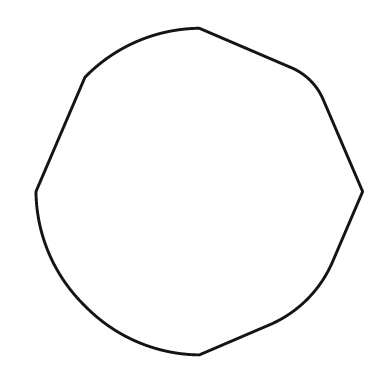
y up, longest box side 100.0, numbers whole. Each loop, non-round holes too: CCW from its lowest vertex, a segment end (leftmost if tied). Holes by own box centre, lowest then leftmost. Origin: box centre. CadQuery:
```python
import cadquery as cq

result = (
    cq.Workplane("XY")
    .moveTo(0.0, -50.0)
    .lineTo(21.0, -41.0)
    .threePointArc((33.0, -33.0), (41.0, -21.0))
    .lineTo(50.0, 0.0)
    .lineTo(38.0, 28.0)
    .threePointArc((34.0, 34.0), (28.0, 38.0))
    .lineTo(0.0, 50.0)
    .threePointArc((-19.0, 46.0), (-35.0, 35.0))
    .lineTo(-50.0, 0.0)
    .threePointArc((-46.0, -19.0), (-35.0, -35.0))
    .threePointArc((-19.0, -46.0), (0.0, -50.0))
    .close()
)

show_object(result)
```